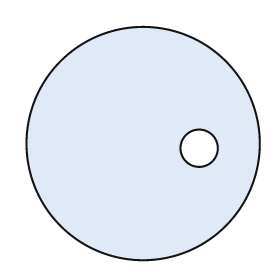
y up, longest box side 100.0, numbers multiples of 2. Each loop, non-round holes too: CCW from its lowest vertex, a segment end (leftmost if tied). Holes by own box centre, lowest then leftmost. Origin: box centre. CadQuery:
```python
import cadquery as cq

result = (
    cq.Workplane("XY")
    .moveTo(0.0, 0.0)
    .circle(50.0)
    .moveTo(24.0, -2.0)
    .circle(8.0)
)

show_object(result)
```